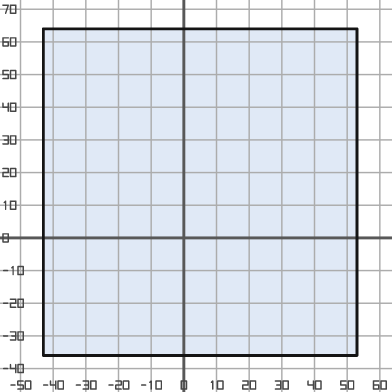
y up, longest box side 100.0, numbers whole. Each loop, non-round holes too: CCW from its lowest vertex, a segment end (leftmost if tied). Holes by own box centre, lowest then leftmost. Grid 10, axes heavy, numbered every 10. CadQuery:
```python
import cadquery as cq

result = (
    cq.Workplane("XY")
    .moveTo(-43.0, -36.0)
    .lineTo(53.0, -36.0)
    .lineTo(53.0, 64.0)
    .lineTo(-43.0, 64.0)
    .close()
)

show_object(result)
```